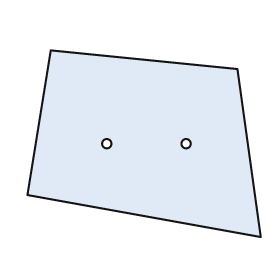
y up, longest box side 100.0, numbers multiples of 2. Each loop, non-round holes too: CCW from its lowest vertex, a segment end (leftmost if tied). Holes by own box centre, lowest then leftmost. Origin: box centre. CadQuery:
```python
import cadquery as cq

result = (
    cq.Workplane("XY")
    .moveTo(50.0, -40.0)
    .lineTo(40.0, 32.0)
    .lineTo(-40.0, 40.0)
    .lineTo(-50.0, -22.0)
    .close()
    .moveTo(-16.0, 0.0)
    .circle(2.0)
    .moveTo(18.0, 0.0)
    .circle(2.0)
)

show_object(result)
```